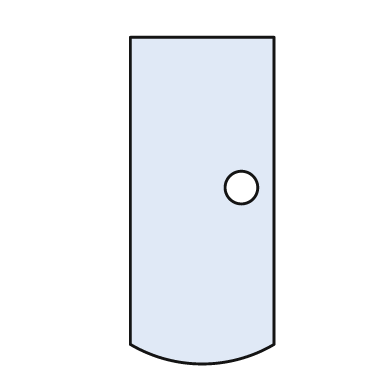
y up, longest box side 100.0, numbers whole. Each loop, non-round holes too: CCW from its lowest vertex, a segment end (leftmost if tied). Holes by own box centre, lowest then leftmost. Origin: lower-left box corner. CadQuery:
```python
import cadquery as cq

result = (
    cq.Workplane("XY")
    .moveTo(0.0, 6.0)
    .threePointArc((22.0, 0.0), (44.0, 6.0))
    .lineTo(44.0, 100.0)
    .lineTo(0.0, 100.0)
    .close()
    .moveTo(34.0, 54.0)
    .circle(5.0)
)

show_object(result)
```